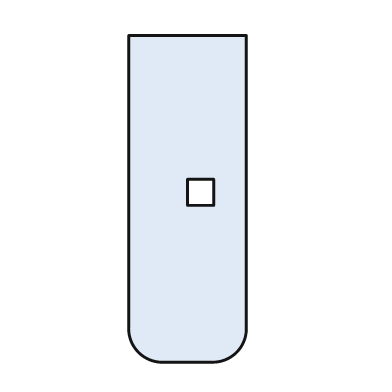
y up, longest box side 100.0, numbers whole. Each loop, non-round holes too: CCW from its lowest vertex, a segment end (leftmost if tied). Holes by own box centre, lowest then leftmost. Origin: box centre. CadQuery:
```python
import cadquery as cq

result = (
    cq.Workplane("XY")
    .moveTo(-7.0, -50.0)
    .lineTo(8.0, -50.0)
    .threePointArc((15.0, -47.0), (18.0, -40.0))
    .lineTo(18.0, 50.0)
    .lineTo(-18.0, 50.0)
    .lineTo(-18.0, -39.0)
    .threePointArc((-15.0, -47.0), (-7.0, -50.0))
    .close()
    .moveTo(0.0, -2.0)
    .lineTo(8.0, -2.0)
    .lineTo(8.0, 6.0)
    .lineTo(0.0, 6.0)
    .close()
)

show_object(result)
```